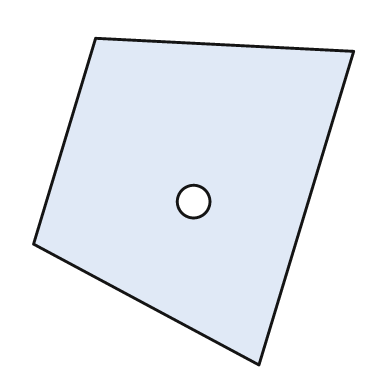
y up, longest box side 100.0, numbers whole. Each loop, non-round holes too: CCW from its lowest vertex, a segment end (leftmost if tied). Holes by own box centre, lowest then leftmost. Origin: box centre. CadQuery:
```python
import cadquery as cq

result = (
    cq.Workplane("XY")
    .moveTo(20.0, -50.0)
    .lineTo(49.0, 46.0)
    .lineTo(-30.0, 50.0)
    .lineTo(-49.0, -13.0)
    .close()
    .moveTo(0.0, 0.0)
    .circle(5.0)
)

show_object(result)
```